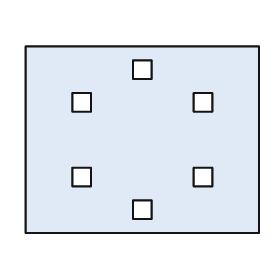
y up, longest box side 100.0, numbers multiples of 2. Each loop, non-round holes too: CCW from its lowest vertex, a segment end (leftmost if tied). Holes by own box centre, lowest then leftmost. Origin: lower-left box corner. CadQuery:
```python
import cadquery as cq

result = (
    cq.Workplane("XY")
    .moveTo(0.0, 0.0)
    .lineTo(100.0, 0.0)
    .lineTo(100.0, 80.0)
    .lineTo(0.0, 80.0)
    .close()
    .moveTo(46.0, 6.0)
    .lineTo(54.0, 6.0)
    .lineTo(54.0, 14.0)
    .lineTo(46.0, 14.0)
    .close()
    .moveTo(20.0, 20.0)
    .lineTo(28.0, 20.0)
    .lineTo(28.0, 28.0)
    .lineTo(20.0, 28.0)
    .close()
    .moveTo(72.0, 20.0)
    .lineTo(80.0, 20.0)
    .lineTo(80.0, 28.0)
    .lineTo(72.0, 28.0)
    .close()
    .moveTo(20.0, 52.0)
    .lineTo(28.0, 52.0)
    .lineTo(28.0, 60.0)
    .lineTo(20.0, 60.0)
    .close()
    .moveTo(72.0, 52.0)
    .lineTo(80.0, 52.0)
    .lineTo(80.0, 60.0)
    .lineTo(72.0, 60.0)
    .close()
    .moveTo(46.0, 66.0)
    .lineTo(54.0, 66.0)
    .lineTo(54.0, 74.0)
    .lineTo(46.0, 74.0)
    .close()
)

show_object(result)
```